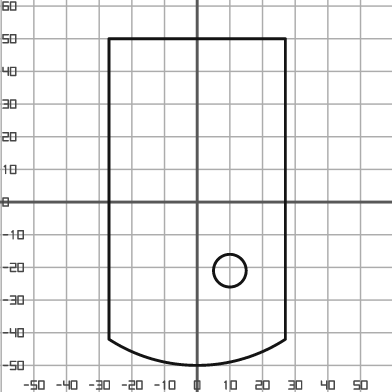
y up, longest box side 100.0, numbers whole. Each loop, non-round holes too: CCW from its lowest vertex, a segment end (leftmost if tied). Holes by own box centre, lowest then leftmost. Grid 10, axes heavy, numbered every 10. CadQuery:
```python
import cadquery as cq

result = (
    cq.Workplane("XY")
    .moveTo(-27.0, -42.0)
    .threePointArc((0.0, -50.0), (27.0, -42.0))
    .lineTo(27.0, 50.0)
    .lineTo(-27.0, 50.0)
    .close()
    .moveTo(10.0, -21.0)
    .circle(5.0)
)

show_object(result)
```